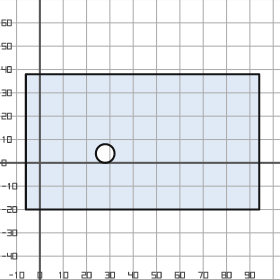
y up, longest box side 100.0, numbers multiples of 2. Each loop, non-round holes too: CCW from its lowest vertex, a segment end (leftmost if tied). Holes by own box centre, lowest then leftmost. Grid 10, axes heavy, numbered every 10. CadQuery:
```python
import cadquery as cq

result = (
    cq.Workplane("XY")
    .moveTo(-6.0, -20.0)
    .lineTo(94.0, -20.0)
    .lineTo(94.0, 38.0)
    .lineTo(-6.0, 38.0)
    .close()
    .moveTo(28.0, 4.0)
    .circle(4.0)
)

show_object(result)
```